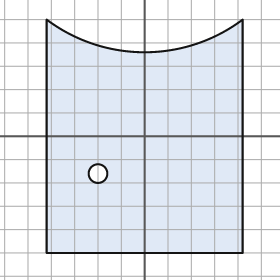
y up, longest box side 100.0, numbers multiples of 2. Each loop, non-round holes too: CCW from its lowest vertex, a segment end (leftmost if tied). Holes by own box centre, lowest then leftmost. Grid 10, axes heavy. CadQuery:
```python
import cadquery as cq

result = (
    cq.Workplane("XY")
    .moveTo(-42.0, -50.0)
    .lineTo(42.0, -50.0)
    .lineTo(42.0, 50.0)
    .threePointArc((0.0, 36.0), (-42.0, 50.0))
    .close()
    .moveTo(-20.0, -16.0)
    .circle(4.0)
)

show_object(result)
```